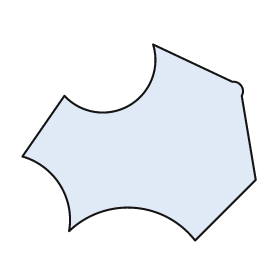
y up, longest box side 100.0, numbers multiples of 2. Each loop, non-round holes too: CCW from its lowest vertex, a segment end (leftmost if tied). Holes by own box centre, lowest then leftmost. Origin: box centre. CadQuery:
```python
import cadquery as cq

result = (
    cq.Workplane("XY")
    .moveTo(24.0, -42.0)
    .lineTo(50.0, -16.0)
    .lineTo(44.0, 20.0)
    .threePointArc((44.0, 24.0), (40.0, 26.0))
    .lineTo(6.0, 42.0)
    .threePointArc((-4.0, 16.0), (-32.0, 20.0))
    .lineTo(-50.0, -6.0)
    .threePointArc((-34.0, -18.0), (-30.0, -38.0))
    .threePointArc((-2.0, -28.0), (24.0, -42.0))
    .close()
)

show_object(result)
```